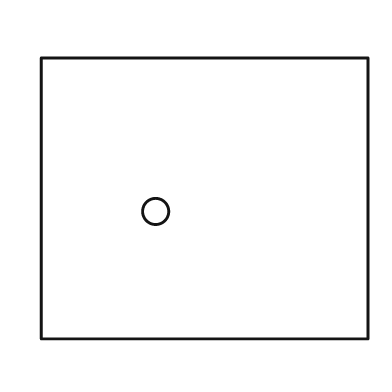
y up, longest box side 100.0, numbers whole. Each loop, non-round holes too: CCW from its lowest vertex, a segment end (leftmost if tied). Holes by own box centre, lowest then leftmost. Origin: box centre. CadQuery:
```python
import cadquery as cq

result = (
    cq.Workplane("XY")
    .moveTo(-50.0, -43.0)
    .lineTo(50.0, -43.0)
    .lineTo(50.0, 43.0)
    .lineTo(-50.0, 43.0)
    .close()
    .moveTo(-15.0, -4.0)
    .circle(4.0)
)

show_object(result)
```